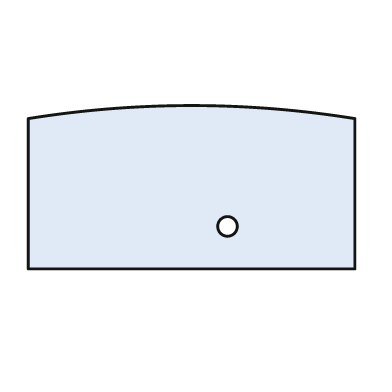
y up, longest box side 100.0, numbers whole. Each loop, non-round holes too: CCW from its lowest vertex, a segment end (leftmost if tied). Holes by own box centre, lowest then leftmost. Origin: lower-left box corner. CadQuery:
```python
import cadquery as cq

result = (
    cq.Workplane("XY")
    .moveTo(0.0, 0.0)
    .lineTo(100.0, 0.0)
    .lineTo(100.0, 46.0)
    .threePointArc((50.0, 50.0), (0.0, 46.0))
    .close()
    .moveTo(61.0, 13.0)
    .circle(3.0)
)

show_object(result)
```